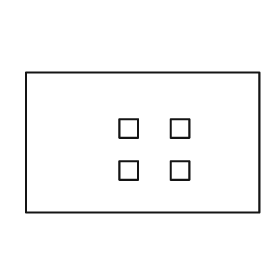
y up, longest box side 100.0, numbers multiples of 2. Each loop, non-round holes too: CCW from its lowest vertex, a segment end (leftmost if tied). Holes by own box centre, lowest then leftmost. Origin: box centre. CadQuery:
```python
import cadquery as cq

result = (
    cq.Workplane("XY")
    .moveTo(-50.0, -30.0)
    .lineTo(50.0, -30.0)
    .lineTo(50.0, 30.0)
    .lineTo(-50.0, 30.0)
    .close()
    .moveTo(-10.0, -16.0)
    .lineTo(-2.0, -16.0)
    .lineTo(-2.0, -8.0)
    .lineTo(-10.0, -8.0)
    .close()
    .moveTo(12.0, -16.0)
    .lineTo(20.0, -16.0)
    .lineTo(20.0, -8.0)
    .lineTo(12.0, -8.0)
    .close()
    .moveTo(-10.0, 2.0)
    .lineTo(-2.0, 2.0)
    .lineTo(-2.0, 10.0)
    .lineTo(-10.0, 10.0)
    .close()
    .moveTo(12.0, 2.0)
    .lineTo(20.0, 2.0)
    .lineTo(20.0, 10.0)
    .lineTo(12.0, 10.0)
    .close()
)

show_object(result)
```